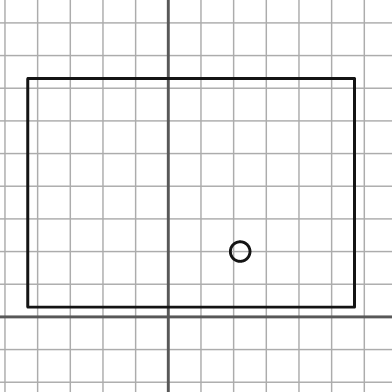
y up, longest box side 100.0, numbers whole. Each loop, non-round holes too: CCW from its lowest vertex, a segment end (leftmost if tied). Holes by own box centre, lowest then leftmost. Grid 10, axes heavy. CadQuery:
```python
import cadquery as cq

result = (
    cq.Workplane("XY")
    .moveTo(-43.0, 3.0)
    .lineTo(57.0, 3.0)
    .lineTo(57.0, 73.0)
    .lineTo(-43.0, 73.0)
    .close()
    .moveTo(22.0, 20.0)
    .circle(3.0)
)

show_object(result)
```